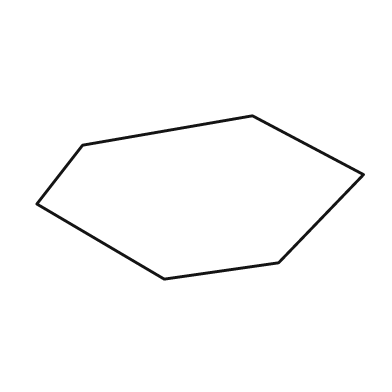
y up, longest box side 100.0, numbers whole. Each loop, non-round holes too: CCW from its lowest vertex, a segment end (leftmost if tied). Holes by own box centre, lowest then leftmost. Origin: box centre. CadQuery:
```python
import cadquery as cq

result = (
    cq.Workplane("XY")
    .moveTo(-11.0, -25.0)
    .lineTo(24.0, -20.0)
    .lineTo(50.0, 7.0)
    .lineTo(16.0, 25.0)
    .lineTo(-36.0, 16.0)
    .lineTo(-50.0, -2.0)
    .close()
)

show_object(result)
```